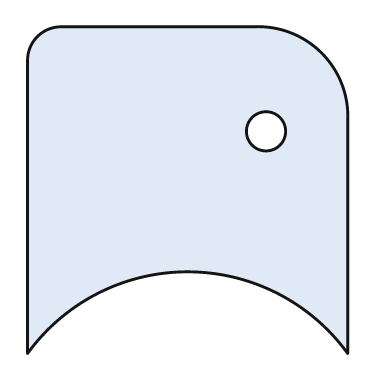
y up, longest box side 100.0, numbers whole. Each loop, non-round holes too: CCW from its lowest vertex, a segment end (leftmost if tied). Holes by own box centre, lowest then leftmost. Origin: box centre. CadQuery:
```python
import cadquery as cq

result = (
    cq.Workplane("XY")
    .moveTo(-49.0, -50.0)
    .threePointArc((0.0, -25.0), (49.0, -50.0))
    .lineTo(49.0, 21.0)
    .threePointArc((41.0, 42.0), (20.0, 50.0))
    .lineTo(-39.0, 50.0)
    .threePointArc((-46.0, 47.0), (-49.0, 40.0))
    .close()
    .moveTo(24.0, 18.0)
    .circle(6.0)
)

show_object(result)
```